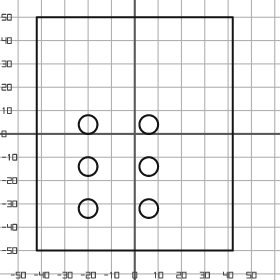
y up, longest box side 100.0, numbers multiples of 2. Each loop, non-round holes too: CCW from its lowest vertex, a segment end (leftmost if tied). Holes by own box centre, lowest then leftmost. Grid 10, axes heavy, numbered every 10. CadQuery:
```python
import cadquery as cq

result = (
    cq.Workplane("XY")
    .moveTo(-42.0, -50.0)
    .lineTo(42.0, -50.0)
    .lineTo(42.0, 50.0)
    .lineTo(-42.0, 50.0)
    .close()
    .moveTo(-20.0, -32.0)
    .circle(4.0)
    .moveTo(6.0, -32.0)
    .circle(4.0)
    .moveTo(-20.0, -14.0)
    .circle(4.0)
    .moveTo(6.0, -14.0)
    .circle(4.0)
    .moveTo(-20.0, 4.0)
    .circle(4.0)
    .moveTo(6.0, 4.0)
    .circle(4.0)
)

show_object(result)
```